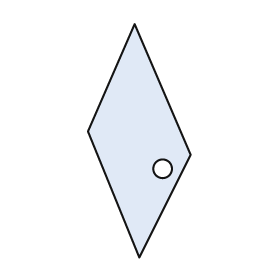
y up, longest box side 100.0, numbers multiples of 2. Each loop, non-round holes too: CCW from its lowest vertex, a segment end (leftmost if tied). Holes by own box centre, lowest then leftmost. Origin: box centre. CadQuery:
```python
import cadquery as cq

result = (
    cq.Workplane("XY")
    .moveTo(0.0, -50.0)
    .lineTo(22.0, -6.0)
    .lineTo(-2.0, 50.0)
    .lineTo(-22.0, 4.0)
    .close()
    .moveTo(10.0, -12.0)
    .circle(4.0)
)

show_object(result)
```